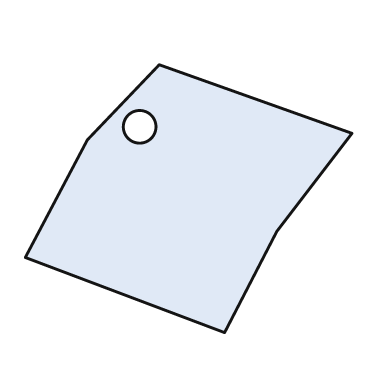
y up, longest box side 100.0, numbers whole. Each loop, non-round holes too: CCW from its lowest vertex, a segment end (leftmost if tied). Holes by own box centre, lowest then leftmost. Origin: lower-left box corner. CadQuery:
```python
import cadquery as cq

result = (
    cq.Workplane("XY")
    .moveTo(61.0, 0.0)
    .lineTo(77.0, 31.0)
    .lineTo(100.0, 61.0)
    .lineTo(41.0, 82.0)
    .lineTo(19.0, 59.0)
    .lineTo(0.0, 23.0)
    .close()
    .moveTo(35.0, 63.0)
    .circle(5.0)
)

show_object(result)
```